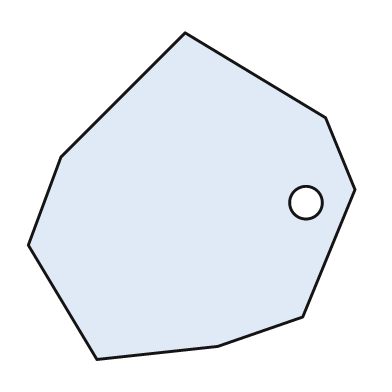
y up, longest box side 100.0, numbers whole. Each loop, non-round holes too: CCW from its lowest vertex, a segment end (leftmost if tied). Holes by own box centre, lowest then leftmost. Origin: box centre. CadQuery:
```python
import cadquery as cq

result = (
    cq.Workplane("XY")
    .moveTo(-29.0, -50.0)
    .lineTo(8.0, -46.0)
    .lineTo(34.0, -37.0)
    .lineTo(50.0, 2.0)
    .lineTo(41.0, 24.0)
    .lineTo(-2.0, 50.0)
    .lineTo(-40.0, 12.0)
    .lineTo(-50.0, -15.0)
    .close()
    .moveTo(35.0, -2.0)
    .circle(5.0)
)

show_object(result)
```